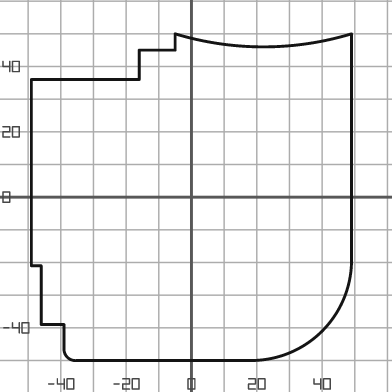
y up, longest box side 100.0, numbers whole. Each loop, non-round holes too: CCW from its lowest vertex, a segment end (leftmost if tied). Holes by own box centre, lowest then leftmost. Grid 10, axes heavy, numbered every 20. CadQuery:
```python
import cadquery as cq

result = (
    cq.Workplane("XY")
    .moveTo(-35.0, -50.0)
    .lineTo(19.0, -50.0)
    .threePointArc((40.0, -41.0), (49.0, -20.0))
    .lineTo(49.0, 50.0)
    .threePointArc((22.0, 46.0), (-5.0, 50.0))
    .lineTo(-5.0, 45.0)
    .lineTo(-16.0, 45.0)
    .lineTo(-16.0, 36.0)
    .lineTo(-49.0, 36.0)
    .lineTo(-49.0, -21.0)
    .lineTo(-46.0, -21.0)
    .lineTo(-46.0, -39.0)
    .lineTo(-39.0, -39.0)
    .lineTo(-39.0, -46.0)
    .threePointArc((-38.0, -49.0), (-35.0, -50.0))
    .close()
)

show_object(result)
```